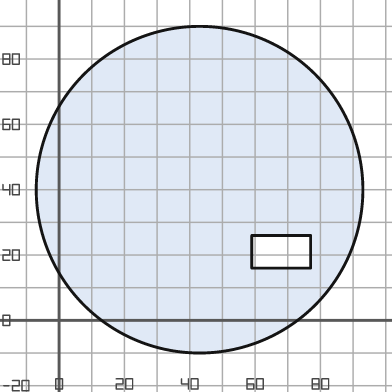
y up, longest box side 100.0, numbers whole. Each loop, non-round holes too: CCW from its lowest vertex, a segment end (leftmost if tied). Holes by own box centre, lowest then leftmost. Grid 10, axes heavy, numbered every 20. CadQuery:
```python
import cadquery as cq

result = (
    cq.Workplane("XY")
    .moveTo(43.0, 40.0)
    .circle(50.0)
    .moveTo(59.0, 16.0)
    .lineTo(77.0, 16.0)
    .lineTo(77.0, 26.0)
    .lineTo(59.0, 26.0)
    .close()
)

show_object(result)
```